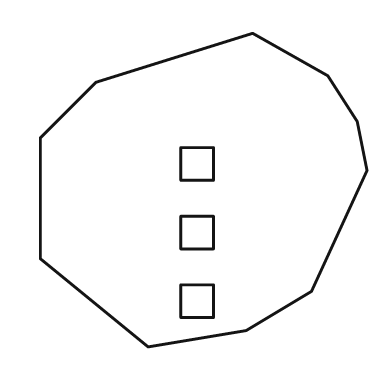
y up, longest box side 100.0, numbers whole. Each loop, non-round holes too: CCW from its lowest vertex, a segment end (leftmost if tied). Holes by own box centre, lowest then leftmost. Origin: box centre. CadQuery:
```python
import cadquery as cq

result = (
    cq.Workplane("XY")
    .moveTo(-17.0, -48.0)
    .lineTo(13.0, -43.0)
    .lineTo(33.0, -31.0)
    .lineTo(50.0, 6.0)
    .lineTo(47.0, 21.0)
    .lineTo(38.0, 35.0)
    .lineTo(15.0, 48.0)
    .lineTo(-33.0, 33.0)
    .lineTo(-50.0, 16.0)
    .lineTo(-50.0, -21.0)
    .close()
    .moveTo(-7.0, -39.0)
    .lineTo(3.0, -39.0)
    .lineTo(3.0, -29.0)
    .lineTo(-7.0, -29.0)
    .close()
    .moveTo(-7.0, -18.0)
    .lineTo(3.0, -18.0)
    .lineTo(3.0, -8.0)
    .lineTo(-7.0, -8.0)
    .close()
    .moveTo(-7.0, 3.0)
    .lineTo(3.0, 3.0)
    .lineTo(3.0, 13.0)
    .lineTo(-7.0, 13.0)
    .close()
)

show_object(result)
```